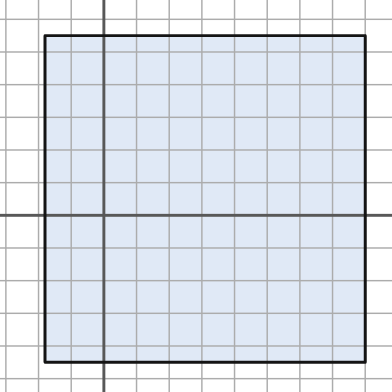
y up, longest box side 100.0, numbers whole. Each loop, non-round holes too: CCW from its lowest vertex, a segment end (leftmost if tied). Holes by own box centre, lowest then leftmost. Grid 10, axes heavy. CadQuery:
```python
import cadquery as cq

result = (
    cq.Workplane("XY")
    .moveTo(-18.0, -45.0)
    .lineTo(80.0, -45.0)
    .lineTo(80.0, 55.0)
    .lineTo(-18.0, 55.0)
    .close()
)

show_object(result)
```